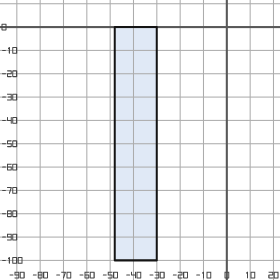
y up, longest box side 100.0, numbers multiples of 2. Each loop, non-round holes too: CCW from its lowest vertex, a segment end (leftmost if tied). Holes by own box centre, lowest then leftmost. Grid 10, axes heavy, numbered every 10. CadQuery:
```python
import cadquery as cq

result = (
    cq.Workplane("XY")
    .moveTo(-48.0, -100.0)
    .lineTo(-30.0, -100.0)
    .lineTo(-30.0, 0.0)
    .lineTo(-48.0, 0.0)
    .close()
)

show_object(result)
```